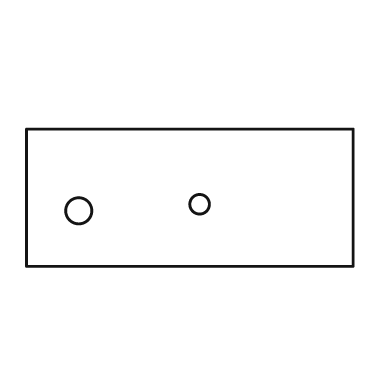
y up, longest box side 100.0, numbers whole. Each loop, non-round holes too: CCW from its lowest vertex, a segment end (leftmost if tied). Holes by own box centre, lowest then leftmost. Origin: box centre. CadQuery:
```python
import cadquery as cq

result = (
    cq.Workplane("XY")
    .moveTo(-50.0, -21.0)
    .lineTo(50.0, -21.0)
    .lineTo(50.0, 21.0)
    .lineTo(-50.0, 21.0)
    .close()
    .moveTo(-34.0, -4.0)
    .circle(4.0)
    .moveTo(3.0, -2.0)
    .circle(3.0)
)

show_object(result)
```